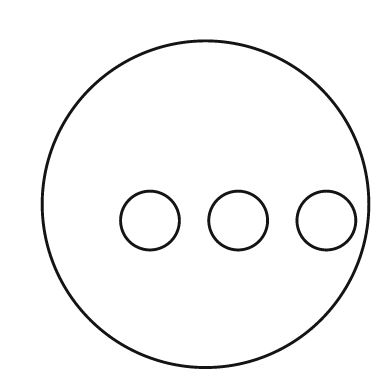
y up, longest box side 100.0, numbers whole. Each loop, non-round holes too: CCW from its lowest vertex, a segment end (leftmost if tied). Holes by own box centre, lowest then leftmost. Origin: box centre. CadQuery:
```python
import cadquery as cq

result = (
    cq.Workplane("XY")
    .moveTo(0.0, 0.0)
    .circle(50.0)
    .moveTo(-17.0, -5.0)
    .circle(9.0)
    .moveTo(10.0, -5.0)
    .circle(9.0)
    .moveTo(37.0, -5.0)
    .circle(9.0)
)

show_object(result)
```